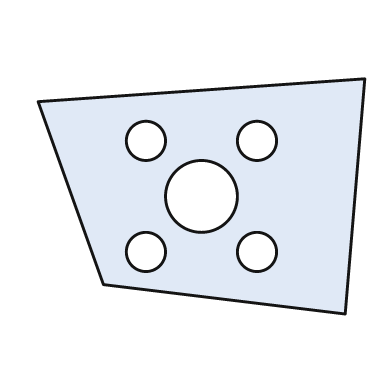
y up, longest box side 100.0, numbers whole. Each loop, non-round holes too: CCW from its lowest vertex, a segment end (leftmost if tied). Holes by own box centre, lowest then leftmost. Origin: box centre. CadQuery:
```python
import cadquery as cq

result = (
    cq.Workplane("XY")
    .moveTo(44.0, -36.0)
    .lineTo(50.0, 36.0)
    .lineTo(-50.0, 29.0)
    .lineTo(-30.0, -27.0)
    .close()
    .moveTo(-17.0, -17.0)
    .circle(6.0)
    .moveTo(17.0, -17.0)
    .circle(6.0)
    .moveTo(0.0, 0.0)
    .circle(11.0)
    .moveTo(-17.0, 17.0)
    .circle(6.0)
    .moveTo(17.0, 17.0)
    .circle(6.0)
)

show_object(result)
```